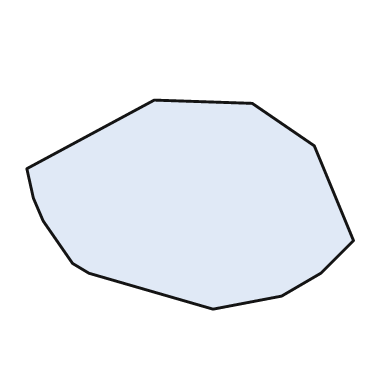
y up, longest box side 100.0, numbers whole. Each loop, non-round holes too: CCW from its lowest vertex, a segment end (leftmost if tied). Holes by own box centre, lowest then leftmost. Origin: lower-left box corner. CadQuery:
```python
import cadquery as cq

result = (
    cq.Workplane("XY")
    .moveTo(57.0, 0.0)
    .lineTo(78.0, 4.0)
    .lineTo(90.0, 11.0)
    .lineTo(100.0, 21.0)
    .lineTo(88.0, 50.0)
    .lineTo(69.0, 63.0)
    .lineTo(39.0, 64.0)
    .lineTo(0.0, 43.0)
    .lineTo(2.0, 34.0)
    .lineTo(5.0, 27.0)
    .lineTo(14.0, 14.0)
    .lineTo(19.0, 11.0)
    .close()
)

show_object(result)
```